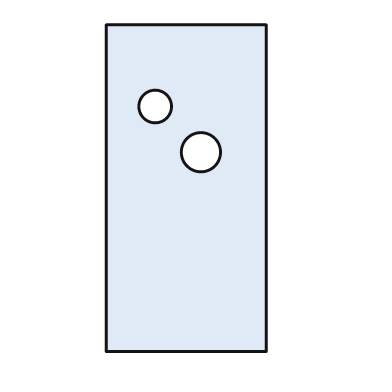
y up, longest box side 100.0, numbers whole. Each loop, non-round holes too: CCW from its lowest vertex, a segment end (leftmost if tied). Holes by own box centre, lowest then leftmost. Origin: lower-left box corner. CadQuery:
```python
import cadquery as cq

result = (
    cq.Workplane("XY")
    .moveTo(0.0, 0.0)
    .lineTo(49.0, 0.0)
    .lineTo(49.0, 100.0)
    .lineTo(0.0, 100.0)
    .close()
    .moveTo(29.0, 61.0)
    .circle(6.0)
    .moveTo(15.0, 75.0)
    .circle(5.0)
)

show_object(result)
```